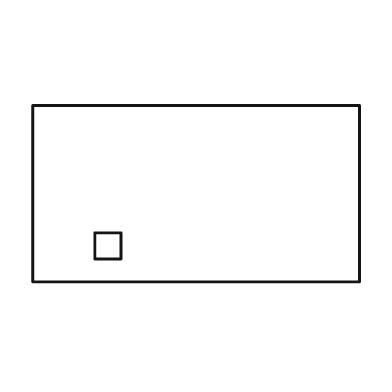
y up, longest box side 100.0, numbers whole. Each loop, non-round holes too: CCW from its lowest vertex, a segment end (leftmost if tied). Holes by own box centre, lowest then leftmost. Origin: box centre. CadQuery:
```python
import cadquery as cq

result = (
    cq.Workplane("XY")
    .moveTo(-50.0, -27.0)
    .lineTo(50.0, -27.0)
    .lineTo(50.0, 27.0)
    .lineTo(-50.0, 27.0)
    .close()
    .moveTo(-31.0, -20.0)
    .lineTo(-23.0, -20.0)
    .lineTo(-23.0, -12.0)
    .lineTo(-31.0, -12.0)
    .close()
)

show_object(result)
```